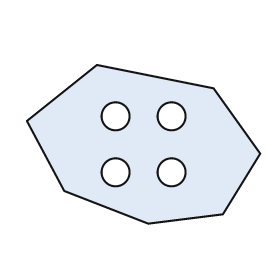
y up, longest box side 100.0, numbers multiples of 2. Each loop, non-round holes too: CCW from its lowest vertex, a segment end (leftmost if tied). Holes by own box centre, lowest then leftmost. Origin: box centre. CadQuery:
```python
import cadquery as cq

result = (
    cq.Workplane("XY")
    .moveTo(2.0, -34.0)
    .lineTo(34.0, -30.0)
    .lineTo(50.0, -4.0)
    .lineTo(30.0, 24.0)
    .lineTo(-20.0, 34.0)
    .lineTo(-50.0, 10.0)
    .lineTo(-34.0, -20.0)
    .close()
    .moveTo(-12.0, -12.0)
    .circle(6.0)
    .moveTo(12.0, -12.0)
    .circle(6.0)
    .moveTo(-12.0, 12.0)
    .circle(6.0)
    .moveTo(12.0, 12.0)
    .circle(6.0)
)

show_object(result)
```